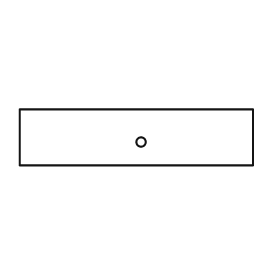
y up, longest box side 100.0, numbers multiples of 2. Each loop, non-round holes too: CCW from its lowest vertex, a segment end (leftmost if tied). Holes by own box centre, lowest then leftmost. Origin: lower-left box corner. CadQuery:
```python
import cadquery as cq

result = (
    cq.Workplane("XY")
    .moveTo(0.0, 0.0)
    .lineTo(100.0, 0.0)
    .lineTo(100.0, 24.0)
    .lineTo(0.0, 24.0)
    .close()
    .moveTo(52.0, 10.0)
    .circle(2.0)
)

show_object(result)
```